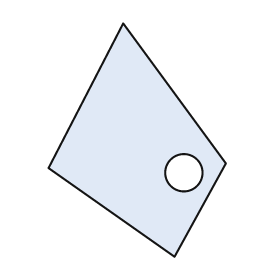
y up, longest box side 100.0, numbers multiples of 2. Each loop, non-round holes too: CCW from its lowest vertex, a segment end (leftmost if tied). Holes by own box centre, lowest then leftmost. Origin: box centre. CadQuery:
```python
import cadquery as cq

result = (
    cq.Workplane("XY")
    .moveTo(16.0, -50.0)
    .lineTo(38.0, -10.0)
    .lineTo(-6.0, 50.0)
    .lineTo(-38.0, -12.0)
    .close()
    .moveTo(20.0, -14.0)
    .circle(8.0)
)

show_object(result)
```